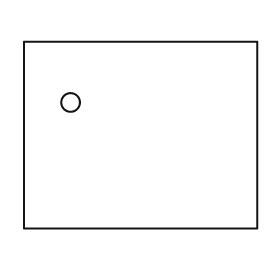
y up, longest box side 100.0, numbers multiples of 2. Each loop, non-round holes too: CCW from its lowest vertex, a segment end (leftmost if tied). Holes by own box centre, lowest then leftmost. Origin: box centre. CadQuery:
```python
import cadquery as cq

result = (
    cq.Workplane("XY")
    .moveTo(-50.0, -40.0)
    .lineTo(50.0, -40.0)
    .lineTo(50.0, 40.0)
    .lineTo(-50.0, 40.0)
    .close()
    .moveTo(-30.0, 14.0)
    .circle(4.0)
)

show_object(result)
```